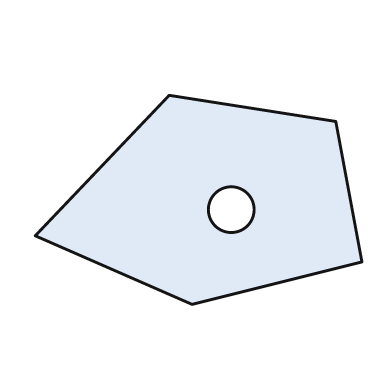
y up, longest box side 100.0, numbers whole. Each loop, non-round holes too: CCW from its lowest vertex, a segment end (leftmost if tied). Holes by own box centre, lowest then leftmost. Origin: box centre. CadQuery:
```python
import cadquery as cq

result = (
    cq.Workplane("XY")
    .moveTo(-2.0, -32.0)
    .lineTo(50.0, -19.0)
    .lineTo(42.0, 24.0)
    .lineTo(-9.0, 32.0)
    .lineTo(-50.0, -11.0)
    .close()
    .moveTo(10.0, -3.0)
    .circle(7.0)
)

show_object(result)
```